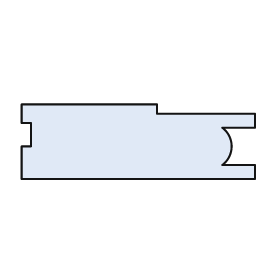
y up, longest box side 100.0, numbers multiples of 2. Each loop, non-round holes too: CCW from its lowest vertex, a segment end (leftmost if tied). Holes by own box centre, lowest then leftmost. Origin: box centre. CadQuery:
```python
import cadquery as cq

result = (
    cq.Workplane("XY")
    .moveTo(-50.0, -16.0)
    .lineTo(50.0, -16.0)
    .lineTo(50.0, -10.0)
    .lineTo(36.0, -10.0)
    .threePointArc((40.0, -2.0), (36.0, 6.0))
    .lineTo(50.0, 6.0)
    .lineTo(50.0, 12.0)
    .lineTo(8.0, 12.0)
    .lineTo(8.0, 16.0)
    .lineTo(-50.0, 16.0)
    .lineTo(-50.0, 8.0)
    .lineTo(-46.0, 8.0)
    .lineTo(-46.0, -2.0)
    .lineTo(-50.0, -2.0)
    .close()
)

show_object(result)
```